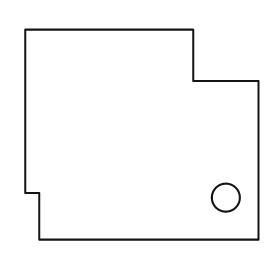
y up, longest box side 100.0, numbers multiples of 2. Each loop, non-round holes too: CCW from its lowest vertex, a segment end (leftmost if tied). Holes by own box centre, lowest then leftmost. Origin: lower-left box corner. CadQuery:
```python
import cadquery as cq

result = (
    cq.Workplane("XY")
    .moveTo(6.0, 0.0)
    .lineTo(100.0, 0.0)
    .lineTo(100.0, 68.0)
    .lineTo(72.0, 68.0)
    .lineTo(72.0, 90.0)
    .lineTo(0.0, 90.0)
    .lineTo(0.0, 20.0)
    .lineTo(6.0, 20.0)
    .close()
    .moveTo(86.0, 18.0)
    .circle(6.0)
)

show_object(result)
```